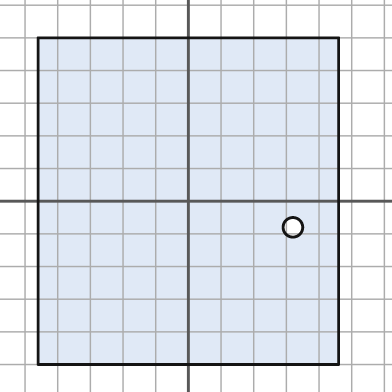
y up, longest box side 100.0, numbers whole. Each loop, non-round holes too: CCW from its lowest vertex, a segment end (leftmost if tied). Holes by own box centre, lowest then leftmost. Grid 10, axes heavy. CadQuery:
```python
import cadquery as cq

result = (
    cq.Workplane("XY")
    .moveTo(-46.0, -50.0)
    .lineTo(46.0, -50.0)
    .lineTo(46.0, 50.0)
    .lineTo(-46.0, 50.0)
    .close()
    .moveTo(32.0, -8.0)
    .circle(3.0)
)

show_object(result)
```